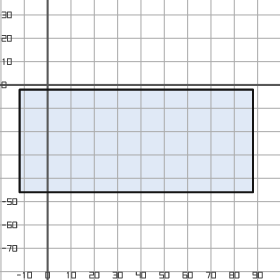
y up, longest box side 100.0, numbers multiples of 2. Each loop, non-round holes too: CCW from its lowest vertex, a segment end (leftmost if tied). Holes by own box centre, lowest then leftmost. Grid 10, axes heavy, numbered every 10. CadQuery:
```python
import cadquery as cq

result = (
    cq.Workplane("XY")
    .moveTo(-12.0, -46.0)
    .lineTo(88.0, -46.0)
    .lineTo(88.0, -2.0)
    .lineTo(-12.0, -2.0)
    .close()
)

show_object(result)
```